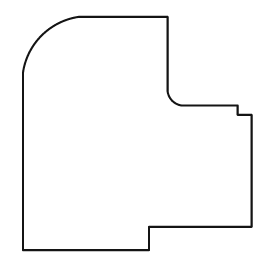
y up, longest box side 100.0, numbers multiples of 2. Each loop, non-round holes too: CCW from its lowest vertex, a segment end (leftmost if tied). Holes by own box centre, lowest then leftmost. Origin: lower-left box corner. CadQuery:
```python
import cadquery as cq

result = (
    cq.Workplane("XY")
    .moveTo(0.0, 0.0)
    .lineTo(54.0, 0.0)
    .lineTo(54.0, 10.0)
    .lineTo(98.0, 10.0)
    .lineTo(98.0, 58.0)
    .lineTo(92.0, 58.0)
    .lineTo(92.0, 62.0)
    .lineTo(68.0, 62.0)
    .threePointArc((64.0, 64.0), (62.0, 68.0))
    .lineTo(62.0, 100.0)
    .lineTo(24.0, 100.0)
    .threePointArc((8.0, 92.0), (0.0, 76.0))
    .close()
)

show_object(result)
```